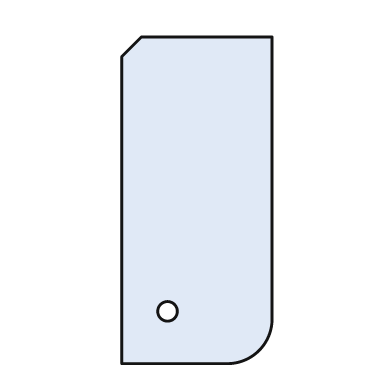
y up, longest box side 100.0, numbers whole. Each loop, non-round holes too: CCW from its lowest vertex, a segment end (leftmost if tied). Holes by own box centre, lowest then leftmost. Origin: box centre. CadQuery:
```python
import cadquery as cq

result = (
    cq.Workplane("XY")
    .moveTo(-23.0, -50.0)
    .lineTo(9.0, -50.0)
    .threePointArc((19.0, -46.0), (23.0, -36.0))
    .lineTo(23.0, 50.0)
    .lineTo(-17.0, 50.0)
    .lineTo(-23.0, 44.0)
    .close()
    .moveTo(-9.0, -34.0)
    .circle(3.0)
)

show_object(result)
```